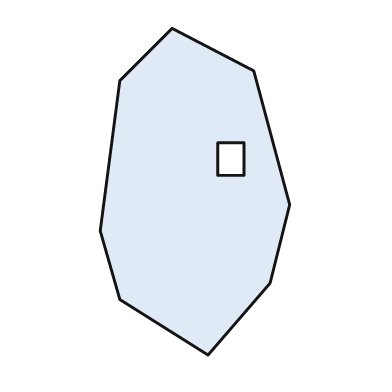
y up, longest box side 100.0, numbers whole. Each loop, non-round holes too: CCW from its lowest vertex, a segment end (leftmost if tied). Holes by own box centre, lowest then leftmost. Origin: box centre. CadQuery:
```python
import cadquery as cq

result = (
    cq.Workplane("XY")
    .moveTo(4.0, -50.0)
    .lineTo(23.0, -28.0)
    .lineTo(29.0, -4.0)
    .lineTo(18.0, 37.0)
    .lineTo(-7.0, 50.0)
    .lineTo(-23.0, 34.0)
    .lineTo(-29.0, -12.0)
    .lineTo(-23.0, -33.0)
    .close()
    .moveTo(7.0, 5.0)
    .lineTo(15.0, 5.0)
    .lineTo(15.0, 15.0)
    .lineTo(7.0, 15.0)
    .close()
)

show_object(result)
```